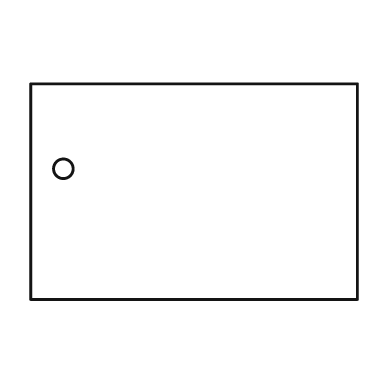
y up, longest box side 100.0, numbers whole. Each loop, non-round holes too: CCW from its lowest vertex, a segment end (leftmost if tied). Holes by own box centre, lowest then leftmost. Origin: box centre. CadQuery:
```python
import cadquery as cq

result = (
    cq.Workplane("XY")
    .moveTo(-50.0, -33.0)
    .lineTo(50.0, -33.0)
    .lineTo(50.0, 33.0)
    .lineTo(-50.0, 33.0)
    .close()
    .moveTo(-40.0, 7.0)
    .circle(3.0)
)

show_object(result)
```